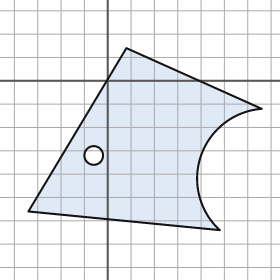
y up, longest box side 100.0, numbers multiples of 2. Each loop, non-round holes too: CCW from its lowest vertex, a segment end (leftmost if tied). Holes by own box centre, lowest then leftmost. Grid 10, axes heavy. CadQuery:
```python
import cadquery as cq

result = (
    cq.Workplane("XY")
    .moveTo(48.0, -64.0)
    .threePointArc((40.0, -32.0), (66.0, -12.0))
    .lineTo(8.0, 14.0)
    .lineTo(-34.0, -56.0)
    .close()
    .moveTo(-6.0, -32.0)
    .circle(4.0)
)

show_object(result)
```